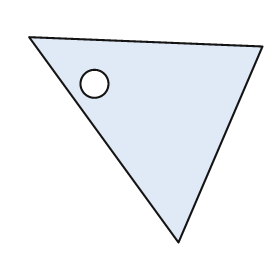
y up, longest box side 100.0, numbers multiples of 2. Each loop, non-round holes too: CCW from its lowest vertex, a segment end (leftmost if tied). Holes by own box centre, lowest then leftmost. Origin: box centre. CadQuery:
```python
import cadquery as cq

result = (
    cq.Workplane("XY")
    .moveTo(14.0, -44.0)
    .lineTo(50.0, 40.0)
    .lineTo(-50.0, 44.0)
    .close()
    .moveTo(-22.0, 24.0)
    .circle(6.0)
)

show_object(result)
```